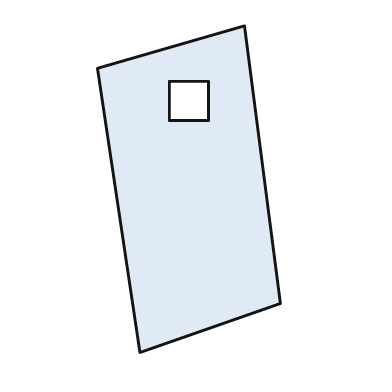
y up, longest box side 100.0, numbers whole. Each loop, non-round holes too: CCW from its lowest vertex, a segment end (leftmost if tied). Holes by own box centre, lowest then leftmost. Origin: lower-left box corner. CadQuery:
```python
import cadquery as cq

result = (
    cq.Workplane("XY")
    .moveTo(13.0, 0.0)
    .lineTo(56.0, 15.0)
    .lineTo(45.0, 100.0)
    .lineTo(0.0, 87.0)
    .close()
    .moveTo(22.0, 71.0)
    .lineTo(34.0, 71.0)
    .lineTo(34.0, 83.0)
    .lineTo(22.0, 83.0)
    .close()
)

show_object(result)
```